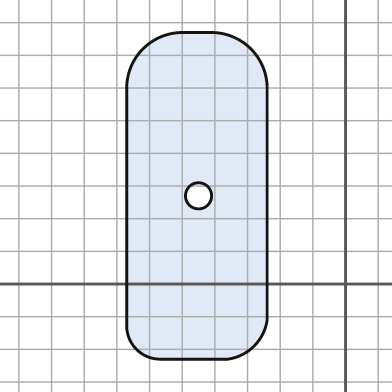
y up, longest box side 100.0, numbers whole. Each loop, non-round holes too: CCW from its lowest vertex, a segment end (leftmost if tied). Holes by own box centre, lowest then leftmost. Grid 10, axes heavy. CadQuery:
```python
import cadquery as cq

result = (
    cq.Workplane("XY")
    .moveTo(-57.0, -23.0)
    .lineTo(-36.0, -23.0)
    .threePointArc((-28.0, -19.0), (-24.0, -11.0))
    .lineTo(-24.0, 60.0)
    .threePointArc((-29.0, 72.0), (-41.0, 77.0))
    .lineTo(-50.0, 77.0)
    .threePointArc((-62.0, 72.0), (-67.0, 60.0))
    .lineTo(-67.0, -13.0)
    .threePointArc((-64.0, -20.0), (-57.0, -23.0))
    .close()
    .moveTo(-45.0, 27.0)
    .circle(4.0)
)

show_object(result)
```